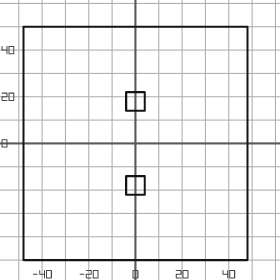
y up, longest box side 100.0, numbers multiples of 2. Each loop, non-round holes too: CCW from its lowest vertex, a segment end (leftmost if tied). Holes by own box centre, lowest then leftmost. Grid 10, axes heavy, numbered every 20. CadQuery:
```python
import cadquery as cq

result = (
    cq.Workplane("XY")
    .moveTo(-48.0, -50.0)
    .lineTo(48.0, -50.0)
    .lineTo(48.0, 50.0)
    .lineTo(-48.0, 50.0)
    .close()
    .moveTo(-4.0, -22.0)
    .lineTo(4.0, -22.0)
    .lineTo(4.0, -14.0)
    .lineTo(-4.0, -14.0)
    .close()
    .moveTo(-4.0, 14.0)
    .lineTo(4.0, 14.0)
    .lineTo(4.0, 22.0)
    .lineTo(-4.0, 22.0)
    .close()
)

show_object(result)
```